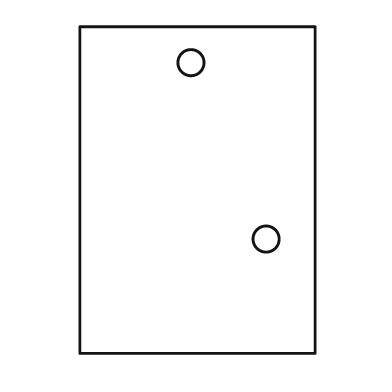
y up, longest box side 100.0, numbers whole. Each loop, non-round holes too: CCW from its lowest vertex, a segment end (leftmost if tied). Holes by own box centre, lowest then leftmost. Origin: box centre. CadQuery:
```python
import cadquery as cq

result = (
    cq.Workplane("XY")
    .moveTo(-36.0, -50.0)
    .lineTo(36.0, -50.0)
    .lineTo(36.0, 50.0)
    .lineTo(-36.0, 50.0)
    .close()
    .moveTo(21.0, -15.0)
    .circle(4.0)
    .moveTo(-2.0, 39.0)
    .circle(4.0)
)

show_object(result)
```